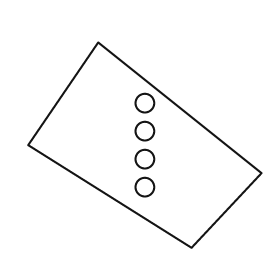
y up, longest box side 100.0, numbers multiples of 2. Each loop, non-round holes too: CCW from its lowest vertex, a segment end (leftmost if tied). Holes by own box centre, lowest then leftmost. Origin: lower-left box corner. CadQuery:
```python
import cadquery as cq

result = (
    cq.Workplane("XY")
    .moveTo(70.0, 0.0)
    .lineTo(100.0, 32.0)
    .lineTo(30.0, 88.0)
    .lineTo(0.0, 44.0)
    .close()
    .moveTo(50.0, 26.0)
    .circle(4.0)
    .moveTo(50.0, 38.0)
    .circle(4.0)
    .moveTo(50.0, 50.0)
    .circle(4.0)
    .moveTo(50.0, 62.0)
    .circle(4.0)
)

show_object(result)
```